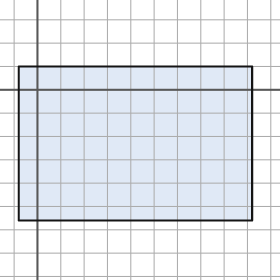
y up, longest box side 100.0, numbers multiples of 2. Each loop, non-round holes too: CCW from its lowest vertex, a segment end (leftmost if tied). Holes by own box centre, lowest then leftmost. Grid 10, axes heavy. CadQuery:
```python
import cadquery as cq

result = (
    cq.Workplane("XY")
    .moveTo(-8.0, -56.0)
    .lineTo(92.0, -56.0)
    .lineTo(92.0, 10.0)
    .lineTo(-8.0, 10.0)
    .close()
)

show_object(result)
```